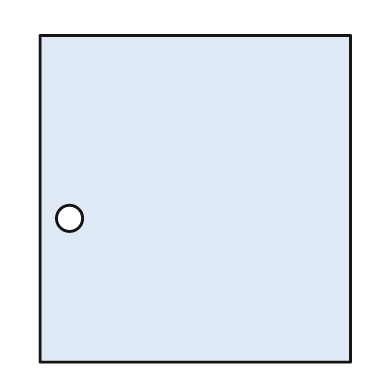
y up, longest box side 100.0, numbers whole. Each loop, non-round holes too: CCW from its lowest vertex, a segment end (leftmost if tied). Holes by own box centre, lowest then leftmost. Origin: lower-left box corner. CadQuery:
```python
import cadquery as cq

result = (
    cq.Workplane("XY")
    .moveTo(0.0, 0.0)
    .lineTo(95.0, 0.0)
    .lineTo(95.0, 100.0)
    .lineTo(0.0, 100.0)
    .close()
    .moveTo(9.0, 44.0)
    .circle(4.0)
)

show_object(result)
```